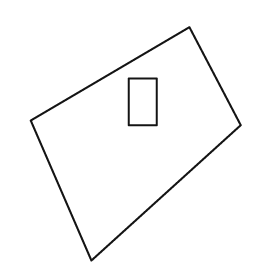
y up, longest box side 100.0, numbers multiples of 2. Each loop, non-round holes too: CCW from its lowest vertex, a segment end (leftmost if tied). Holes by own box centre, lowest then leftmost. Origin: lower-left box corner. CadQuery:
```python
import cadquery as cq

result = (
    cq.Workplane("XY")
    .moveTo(26.0, 0.0)
    .lineTo(90.0, 58.0)
    .lineTo(68.0, 100.0)
    .lineTo(0.0, 60.0)
    .close()
    .moveTo(42.0, 58.0)
    .lineTo(54.0, 58.0)
    .lineTo(54.0, 78.0)
    .lineTo(42.0, 78.0)
    .close()
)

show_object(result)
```